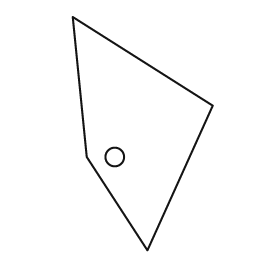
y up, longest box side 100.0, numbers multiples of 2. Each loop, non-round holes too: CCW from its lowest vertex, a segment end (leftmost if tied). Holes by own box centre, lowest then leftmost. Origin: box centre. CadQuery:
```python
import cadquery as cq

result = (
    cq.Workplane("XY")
    .moveTo(2.0, -50.0)
    .lineTo(30.0, 12.0)
    .lineTo(-30.0, 50.0)
    .lineTo(-24.0, -10.0)
    .close()
    .moveTo(-12.0, -10.0)
    .circle(4.0)
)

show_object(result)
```